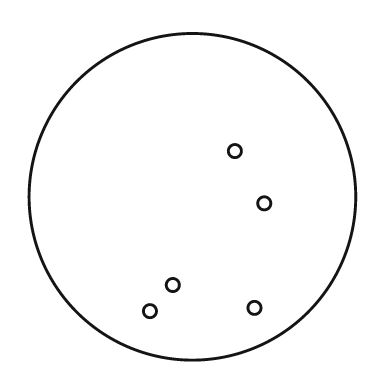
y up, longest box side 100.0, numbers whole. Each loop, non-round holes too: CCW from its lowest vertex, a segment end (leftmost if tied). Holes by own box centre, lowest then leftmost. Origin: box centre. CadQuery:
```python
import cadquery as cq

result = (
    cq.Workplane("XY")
    .moveTo(0.0, 0.0)
    .circle(50.0)
    .moveTo(-13.0, -35.0)
    .circle(2.0)
    .moveTo(19.0, -34.0)
    .circle(2.0)
    .moveTo(-6.0, -27.0)
    .circle(2.0)
    .moveTo(22.0, -2.0)
    .circle(2.0)
    .moveTo(13.0, 14.0)
    .circle(2.0)
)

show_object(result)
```